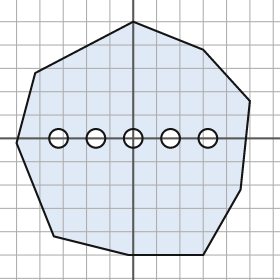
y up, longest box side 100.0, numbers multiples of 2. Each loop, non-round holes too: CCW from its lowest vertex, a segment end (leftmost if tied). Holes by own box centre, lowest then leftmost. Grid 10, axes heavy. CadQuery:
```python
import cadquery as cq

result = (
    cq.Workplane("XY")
    .moveTo(-2.0, -50.0)
    .lineTo(30.0, -50.0)
    .lineTo(46.0, -22.0)
    .lineTo(50.0, 16.0)
    .lineTo(30.0, 38.0)
    .lineTo(0.0, 50.0)
    .lineTo(-42.0, 28.0)
    .lineTo(-50.0, -2.0)
    .lineTo(-34.0, -42.0)
    .close()
    .moveTo(-32.0, 0.0)
    .circle(4.0)
    .moveTo(-16.0, 0.0)
    .circle(4.0)
    .moveTo(0.0, 0.0)
    .circle(4.0)
    .moveTo(16.0, 0.0)
    .circle(4.0)
    .moveTo(32.0, 0.0)
    .circle(4.0)
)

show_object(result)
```